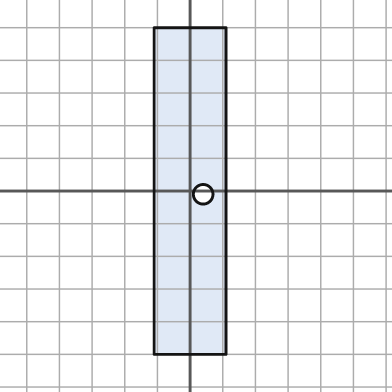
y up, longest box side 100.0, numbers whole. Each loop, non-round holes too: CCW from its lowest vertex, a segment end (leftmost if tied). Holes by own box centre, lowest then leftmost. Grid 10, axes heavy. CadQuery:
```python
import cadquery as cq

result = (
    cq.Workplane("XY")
    .moveTo(-11.0, -50.0)
    .lineTo(11.0, -50.0)
    .lineTo(11.0, 50.0)
    .lineTo(-11.0, 50.0)
    .close()
    .moveTo(4.0, -1.0)
    .circle(3.0)
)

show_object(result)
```